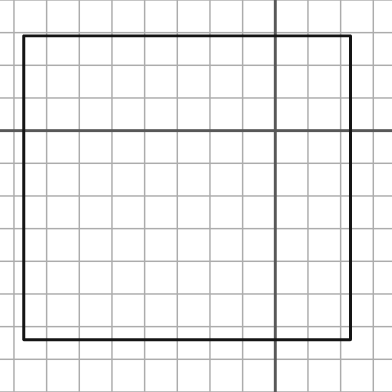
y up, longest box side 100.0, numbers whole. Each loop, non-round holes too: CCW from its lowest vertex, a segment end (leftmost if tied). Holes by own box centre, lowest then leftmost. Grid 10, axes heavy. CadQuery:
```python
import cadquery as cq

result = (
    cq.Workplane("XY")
    .moveTo(-77.0, -64.0)
    .lineTo(23.0, -64.0)
    .lineTo(23.0, 29.0)
    .lineTo(-77.0, 29.0)
    .close()
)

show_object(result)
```